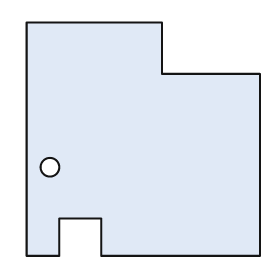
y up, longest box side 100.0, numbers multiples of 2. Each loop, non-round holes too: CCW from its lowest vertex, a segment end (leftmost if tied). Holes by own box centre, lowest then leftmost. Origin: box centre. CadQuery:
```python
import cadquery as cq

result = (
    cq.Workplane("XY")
    .moveTo(-50.0, -50.0)
    .lineTo(-36.0, -50.0)
    .lineTo(-36.0, -34.0)
    .lineTo(-18.0, -34.0)
    .lineTo(-18.0, -50.0)
    .lineTo(50.0, -50.0)
    .lineTo(50.0, 28.0)
    .lineTo(8.0, 28.0)
    .lineTo(8.0, 50.0)
    .lineTo(-50.0, 50.0)
    .close()
    .moveTo(-40.0, -12.0)
    .circle(4.0)
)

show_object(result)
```